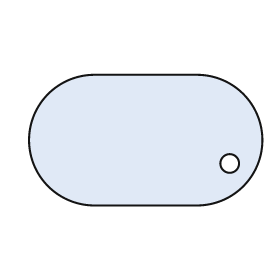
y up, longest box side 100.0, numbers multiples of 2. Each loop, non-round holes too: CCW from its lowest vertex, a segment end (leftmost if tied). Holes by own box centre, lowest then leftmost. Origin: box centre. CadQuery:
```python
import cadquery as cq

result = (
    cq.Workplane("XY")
    .moveTo(-22.0, -28.0)
    .lineTo(22.0, -28.0)
    .threePointArc((50.0, 0.0), (22.0, 28.0))
    .lineTo(-22.0, 28.0)
    .threePointArc((-50.0, 0.0), (-22.0, -28.0))
    .close()
    .moveTo(36.0, -10.0)
    .circle(4.0)
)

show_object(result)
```